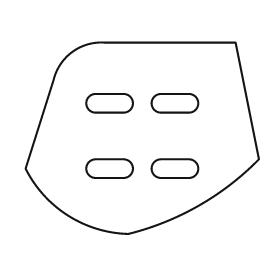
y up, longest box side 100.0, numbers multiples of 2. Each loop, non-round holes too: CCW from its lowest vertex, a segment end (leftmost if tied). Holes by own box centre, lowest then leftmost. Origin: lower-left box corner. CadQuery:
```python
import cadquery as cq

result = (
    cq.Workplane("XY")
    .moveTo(44.0, 0.0)
    .threePointArc((74.0, 12.0), (100.0, 32.0))
    .lineTo(90.0, 82.0)
    .lineTo(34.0, 82.0)
    .threePointArc((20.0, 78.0), (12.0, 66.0))
    .lineTo(0.0, 28.0)
    .threePointArc((18.0, 8.0), (44.0, 0.0))
    .close()
    .moveTo(30.0, 24.0)
    .lineTo(42.0, 24.0)
    .threePointArc((46.0, 28.0), (42.0, 32.0))
    .lineTo(30.0, 32.0)
    .threePointArc((26.0, 28.0), (30.0, 24.0))
    .close()
    .moveTo(58.0, 24.0)
    .lineTo(70.0, 24.0)
    .threePointArc((74.0, 28.0), (70.0, 32.0))
    .lineTo(58.0, 32.0)
    .threePointArc((54.0, 28.0), (58.0, 24.0))
    .close()
    .moveTo(30.0, 52.0)
    .lineTo(42.0, 52.0)
    .threePointArc((46.0, 56.0), (42.0, 60.0))
    .lineTo(30.0, 60.0)
    .threePointArc((26.0, 56.0), (30.0, 52.0))
    .close()
    .moveTo(58.0, 52.0)
    .lineTo(70.0, 52.0)
    .threePointArc((74.0, 56.0), (70.0, 60.0))
    .lineTo(58.0, 60.0)
    .threePointArc((54.0, 56.0), (58.0, 52.0))
    .close()
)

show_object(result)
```